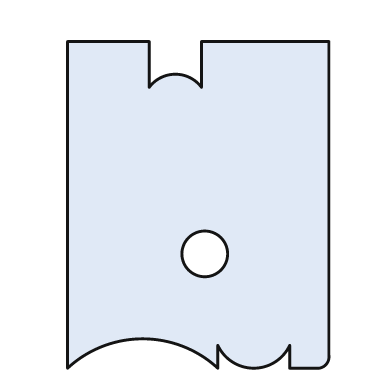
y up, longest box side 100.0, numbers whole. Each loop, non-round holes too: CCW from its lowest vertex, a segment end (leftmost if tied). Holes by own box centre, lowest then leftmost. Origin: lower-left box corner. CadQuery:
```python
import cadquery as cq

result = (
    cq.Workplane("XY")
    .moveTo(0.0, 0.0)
    .threePointArc((23.0, 9.0), (46.0, 0.0))
    .lineTo(46.0, 7.0)
    .threePointArc((57.0, 0.0), (68.0, 7.0))
    .lineTo(68.0, 0.0)
    .lineTo(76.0, 0.0)
    .threePointArc((79.0, 1.0), (80.0, 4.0))
    .lineTo(80.0, 100.0)
    .lineTo(41.0, 100.0)
    .lineTo(41.0, 86.0)
    .threePointArc((33.0, 90.0), (25.0, 86.0))
    .lineTo(25.0, 100.0)
    .lineTo(0.0, 100.0)
    .close()
    .moveTo(42.0, 35.0)
    .circle(7.0)
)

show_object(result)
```